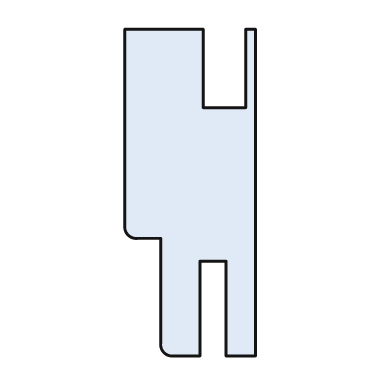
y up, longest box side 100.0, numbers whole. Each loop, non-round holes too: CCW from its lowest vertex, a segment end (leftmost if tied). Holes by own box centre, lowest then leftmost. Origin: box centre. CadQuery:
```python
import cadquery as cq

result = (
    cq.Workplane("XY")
    .moveTo(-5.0, -50.0)
    .lineTo(3.0, -50.0)
    .lineTo(3.0, -21.0)
    .lineTo(11.0, -21.0)
    .lineTo(11.0, -50.0)
    .lineTo(20.0, -50.0)
    .lineTo(20.0, 50.0)
    .lineTo(17.0, 50.0)
    .lineTo(17.0, 26.0)
    .lineTo(4.0, 26.0)
    .lineTo(4.0, 50.0)
    .lineTo(-20.0, 50.0)
    .lineTo(-20.0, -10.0)
    .threePointArc((-19.0, -13.0), (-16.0, -14.0))
    .lineTo(-9.0, -14.0)
    .lineTo(-9.0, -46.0)
    .threePointArc((-8.0, -49.0), (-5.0, -50.0))
    .close()
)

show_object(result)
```